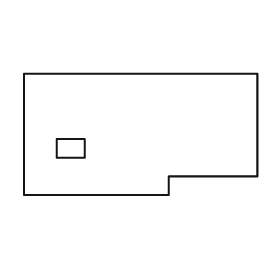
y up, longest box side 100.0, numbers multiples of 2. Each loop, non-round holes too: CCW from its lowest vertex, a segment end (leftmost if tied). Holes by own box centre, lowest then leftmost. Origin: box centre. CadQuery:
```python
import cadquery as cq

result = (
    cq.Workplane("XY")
    .moveTo(-50.0, -26.0)
    .lineTo(12.0, -26.0)
    .lineTo(12.0, -18.0)
    .lineTo(50.0, -18.0)
    .lineTo(50.0, 26.0)
    .lineTo(-50.0, 26.0)
    .close()
    .moveTo(-36.0, -10.0)
    .lineTo(-24.0, -10.0)
    .lineTo(-24.0, -2.0)
    .lineTo(-36.0, -2.0)
    .close()
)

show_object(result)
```